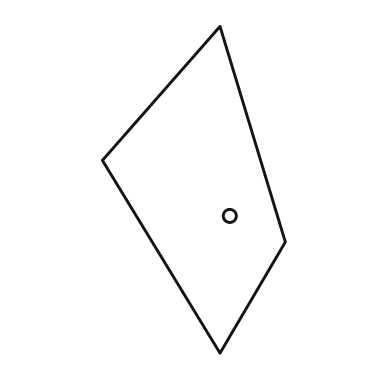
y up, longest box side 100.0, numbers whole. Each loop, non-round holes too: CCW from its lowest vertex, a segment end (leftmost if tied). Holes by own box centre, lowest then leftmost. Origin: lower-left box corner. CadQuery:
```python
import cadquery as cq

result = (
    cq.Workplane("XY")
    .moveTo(36.0, 0.0)
    .lineTo(56.0, 34.0)
    .lineTo(36.0, 100.0)
    .lineTo(0.0, 59.0)
    .close()
    .moveTo(39.0, 42.0)
    .circle(2.0)
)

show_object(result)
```